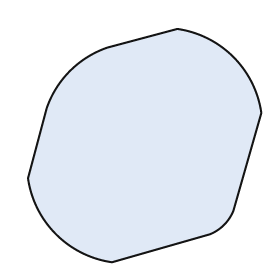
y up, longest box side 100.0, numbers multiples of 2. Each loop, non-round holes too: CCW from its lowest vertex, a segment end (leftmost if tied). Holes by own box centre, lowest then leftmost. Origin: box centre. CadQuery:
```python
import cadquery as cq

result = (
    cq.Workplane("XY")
    .moveTo(-14.0, -50.0)
    .lineTo(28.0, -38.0)
    .threePointArc((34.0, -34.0), (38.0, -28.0))
    .lineTo(50.0, 14.0)
    .threePointArc((38.0, 38.0), (14.0, 50.0))
    .lineTo(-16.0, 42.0)
    .threePointArc((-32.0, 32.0), (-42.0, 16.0))
    .lineTo(-50.0, -14.0)
    .threePointArc((-38.0, -38.0), (-14.0, -50.0))
    .close()
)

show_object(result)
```